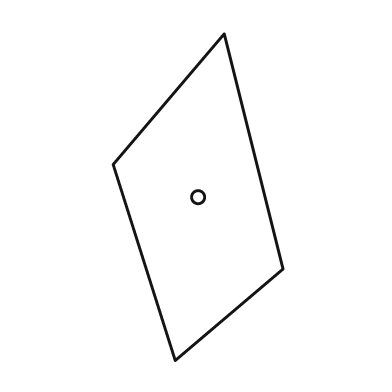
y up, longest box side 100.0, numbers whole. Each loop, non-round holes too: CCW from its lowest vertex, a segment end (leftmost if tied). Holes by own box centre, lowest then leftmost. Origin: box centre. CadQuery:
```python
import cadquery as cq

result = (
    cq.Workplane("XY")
    .moveTo(-7.0, -50.0)
    .lineTo(26.0, -22.0)
    .lineTo(8.0, 50.0)
    .lineTo(-26.0, 10.0)
    .close()
    .moveTo(0.0, 0.0)
    .circle(2.0)
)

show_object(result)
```